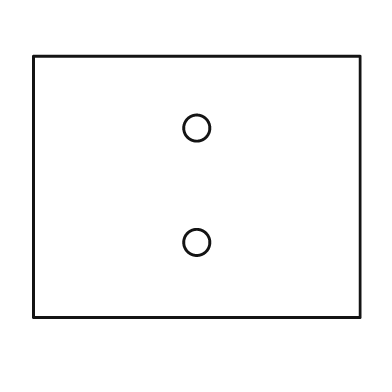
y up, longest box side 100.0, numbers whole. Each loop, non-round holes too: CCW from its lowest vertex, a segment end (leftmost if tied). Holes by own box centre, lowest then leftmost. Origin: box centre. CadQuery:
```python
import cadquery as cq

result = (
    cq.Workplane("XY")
    .moveTo(-50.0, -40.0)
    .lineTo(50.0, -40.0)
    .lineTo(50.0, 40.0)
    .lineTo(-50.0, 40.0)
    .close()
    .moveTo(0.0, -17.0)
    .circle(4.0)
    .moveTo(0.0, 18.0)
    .circle(4.0)
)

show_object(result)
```